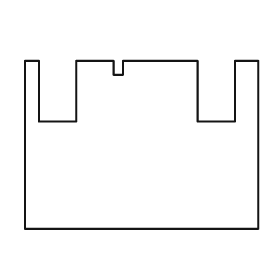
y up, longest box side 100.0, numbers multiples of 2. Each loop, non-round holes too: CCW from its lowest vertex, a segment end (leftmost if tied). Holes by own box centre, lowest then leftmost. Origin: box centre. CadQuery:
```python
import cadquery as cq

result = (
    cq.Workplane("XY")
    .moveTo(-50.0, -36.0)
    .lineTo(50.0, -36.0)
    .lineTo(50.0, 36.0)
    .lineTo(40.0, 36.0)
    .lineTo(40.0, 10.0)
    .lineTo(24.0, 10.0)
    .lineTo(24.0, 36.0)
    .lineTo(-8.0, 36.0)
    .lineTo(-8.0, 30.0)
    .lineTo(-12.0, 30.0)
    .lineTo(-12.0, 36.0)
    .lineTo(-28.0, 36.0)
    .lineTo(-28.0, 10.0)
    .lineTo(-44.0, 10.0)
    .lineTo(-44.0, 36.0)
    .lineTo(-50.0, 36.0)
    .close()
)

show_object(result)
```